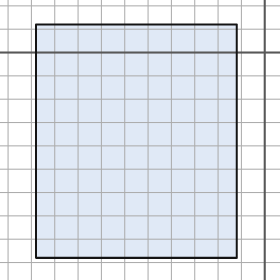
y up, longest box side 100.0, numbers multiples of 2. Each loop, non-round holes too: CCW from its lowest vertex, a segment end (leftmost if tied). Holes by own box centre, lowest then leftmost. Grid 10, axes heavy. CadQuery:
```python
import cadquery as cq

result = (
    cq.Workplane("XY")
    .moveTo(-98.0, -88.0)
    .lineTo(-12.0, -88.0)
    .lineTo(-12.0, 12.0)
    .lineTo(-98.0, 12.0)
    .close()
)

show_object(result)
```